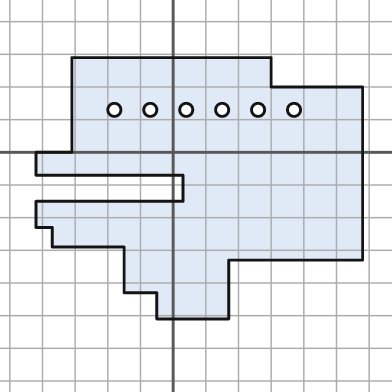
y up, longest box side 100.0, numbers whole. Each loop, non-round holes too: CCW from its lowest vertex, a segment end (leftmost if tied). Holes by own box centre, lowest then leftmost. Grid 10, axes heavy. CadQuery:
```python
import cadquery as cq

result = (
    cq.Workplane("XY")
    .moveTo(-5.0, -51.0)
    .lineTo(17.0, -51.0)
    .lineTo(17.0, -33.0)
    .lineTo(58.0, -33.0)
    .lineTo(58.0, 20.0)
    .lineTo(30.0, 20.0)
    .lineTo(30.0, 29.0)
    .lineTo(-31.0, 29.0)
    .lineTo(-31.0, 0.0)
    .lineTo(-42.0, 0.0)
    .lineTo(-42.0, -7.0)
    .lineTo(3.0, -7.0)
    .lineTo(3.0, -15.0)
    .lineTo(-42.0, -15.0)
    .lineTo(-42.0, -23.0)
    .lineTo(-37.0, -23.0)
    .lineTo(-37.0, -29.0)
    .lineTo(-15.0, -29.0)
    .lineTo(-15.0, -43.0)
    .lineTo(-5.0, -43.0)
    .close()
    .moveTo(-18.0, 13.0)
    .circle(2.0)
    .moveTo(-7.0, 13.0)
    .circle(2.0)
    .moveTo(4.0, 13.0)
    .circle(2.0)
    .moveTo(15.0, 13.0)
    .circle(2.0)
    .moveTo(26.0, 13.0)
    .circle(2.0)
    .moveTo(37.0, 13.0)
    .circle(2.0)
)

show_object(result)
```